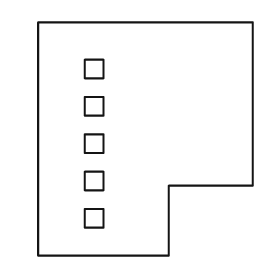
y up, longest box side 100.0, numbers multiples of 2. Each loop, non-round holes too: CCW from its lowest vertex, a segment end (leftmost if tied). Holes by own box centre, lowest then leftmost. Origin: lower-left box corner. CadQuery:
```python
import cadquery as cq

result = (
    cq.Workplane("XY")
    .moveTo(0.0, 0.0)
    .lineTo(56.0, 0.0)
    .lineTo(56.0, 30.0)
    .lineTo(92.0, 30.0)
    .lineTo(92.0, 100.0)
    .lineTo(0.0, 100.0)
    .close()
    .moveTo(20.0, 12.0)
    .lineTo(28.0, 12.0)
    .lineTo(28.0, 20.0)
    .lineTo(20.0, 20.0)
    .close()
    .moveTo(20.0, 28.0)
    .lineTo(28.0, 28.0)
    .lineTo(28.0, 36.0)
    .lineTo(20.0, 36.0)
    .close()
    .moveTo(20.0, 44.0)
    .lineTo(28.0, 44.0)
    .lineTo(28.0, 52.0)
    .lineTo(20.0, 52.0)
    .close()
    .moveTo(20.0, 60.0)
    .lineTo(28.0, 60.0)
    .lineTo(28.0, 68.0)
    .lineTo(20.0, 68.0)
    .close()
    .moveTo(20.0, 76.0)
    .lineTo(28.0, 76.0)
    .lineTo(28.0, 84.0)
    .lineTo(20.0, 84.0)
    .close()
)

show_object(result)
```